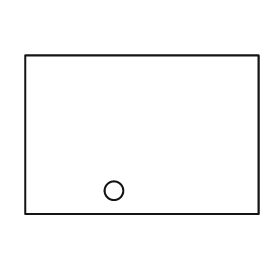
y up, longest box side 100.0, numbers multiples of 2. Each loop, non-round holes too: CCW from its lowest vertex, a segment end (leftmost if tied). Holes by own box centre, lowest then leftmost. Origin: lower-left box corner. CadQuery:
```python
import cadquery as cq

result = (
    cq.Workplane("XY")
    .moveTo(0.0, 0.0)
    .lineTo(100.0, 0.0)
    .lineTo(100.0, 68.0)
    .lineTo(0.0, 68.0)
    .close()
    .moveTo(38.0, 10.0)
    .circle(4.0)
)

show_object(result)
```